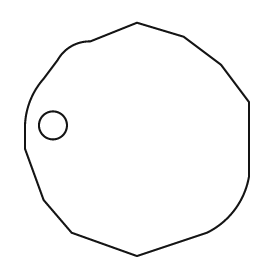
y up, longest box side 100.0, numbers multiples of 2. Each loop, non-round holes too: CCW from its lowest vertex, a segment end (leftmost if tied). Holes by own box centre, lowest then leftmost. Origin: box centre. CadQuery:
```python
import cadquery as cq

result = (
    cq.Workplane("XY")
    .moveTo(0.0, -50.0)
    .lineTo(30.0, -40.0)
    .threePointArc((42.0, -30.0), (48.0, -16.0))
    .lineTo(48.0, 16.0)
    .lineTo(36.0, 32.0)
    .lineTo(20.0, 44.0)
    .lineTo(0.0, 50.0)
    .lineTo(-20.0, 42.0)
    .threePointArc((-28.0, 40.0), (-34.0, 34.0))
    .lineTo(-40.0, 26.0)
    .threePointArc((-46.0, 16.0), (-48.0, 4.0))
    .lineTo(-48.0, -4.0)
    .lineTo(-40.0, -26.0)
    .lineTo(-28.0, -40.0)
    .close()
    .moveTo(-36.0, 6.0)
    .circle(6.0)
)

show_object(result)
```